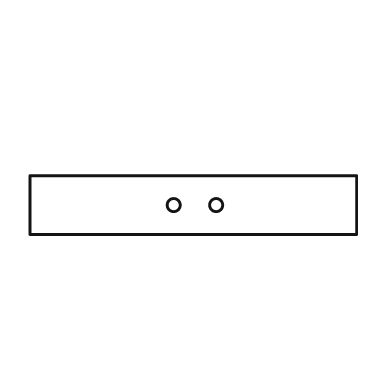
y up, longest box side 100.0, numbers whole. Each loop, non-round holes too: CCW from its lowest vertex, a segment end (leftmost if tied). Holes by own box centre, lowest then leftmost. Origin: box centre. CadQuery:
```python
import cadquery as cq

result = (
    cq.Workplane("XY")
    .moveTo(-50.0, -9.0)
    .lineTo(50.0, -9.0)
    .lineTo(50.0, 9.0)
    .lineTo(-50.0, 9.0)
    .close()
    .moveTo(-6.0, 0.0)
    .circle(2.0)
    .moveTo(7.0, 0.0)
    .circle(2.0)
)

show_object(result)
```